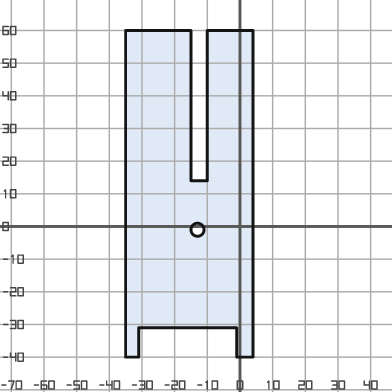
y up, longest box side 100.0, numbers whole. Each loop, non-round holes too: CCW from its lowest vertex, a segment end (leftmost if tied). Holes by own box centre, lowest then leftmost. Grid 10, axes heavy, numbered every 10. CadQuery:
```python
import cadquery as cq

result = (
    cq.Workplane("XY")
    .moveTo(-35.0, -40.0)
    .lineTo(-31.0, -40.0)
    .lineTo(-31.0, -31.0)
    .lineTo(-1.0, -31.0)
    .lineTo(-1.0, -40.0)
    .lineTo(4.0, -40.0)
    .lineTo(4.0, 60.0)
    .lineTo(-10.0, 60.0)
    .lineTo(-10.0, 14.0)
    .lineTo(-15.0, 14.0)
    .lineTo(-15.0, 60.0)
    .lineTo(-35.0, 60.0)
    .close()
    .moveTo(-13.0, -1.0)
    .circle(2.0)
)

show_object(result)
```